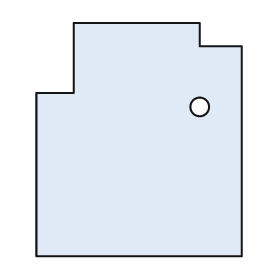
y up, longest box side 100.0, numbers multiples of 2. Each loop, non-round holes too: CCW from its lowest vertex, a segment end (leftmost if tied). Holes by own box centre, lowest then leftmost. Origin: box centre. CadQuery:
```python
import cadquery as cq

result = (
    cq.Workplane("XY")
    .moveTo(-44.0, -50.0)
    .lineTo(44.0, -50.0)
    .lineTo(44.0, 40.0)
    .lineTo(26.0, 40.0)
    .lineTo(26.0, 50.0)
    .lineTo(-28.0, 50.0)
    .lineTo(-28.0, 20.0)
    .lineTo(-44.0, 20.0)
    .close()
    .moveTo(26.0, 14.0)
    .circle(4.0)
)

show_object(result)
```